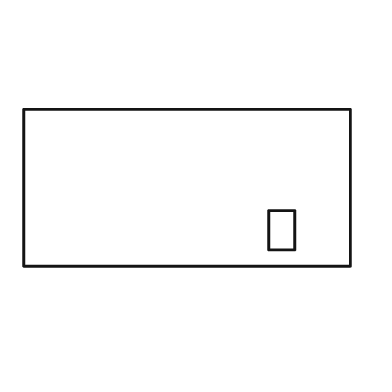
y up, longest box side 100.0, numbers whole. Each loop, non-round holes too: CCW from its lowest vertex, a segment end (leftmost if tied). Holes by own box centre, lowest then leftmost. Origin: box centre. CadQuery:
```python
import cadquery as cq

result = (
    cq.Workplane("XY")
    .moveTo(-50.0, -24.0)
    .lineTo(50.0, -24.0)
    .lineTo(50.0, 24.0)
    .lineTo(-50.0, 24.0)
    .close()
    .moveTo(25.0, -19.0)
    .lineTo(33.0, -19.0)
    .lineTo(33.0, -7.0)
    .lineTo(25.0, -7.0)
    .close()
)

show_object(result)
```